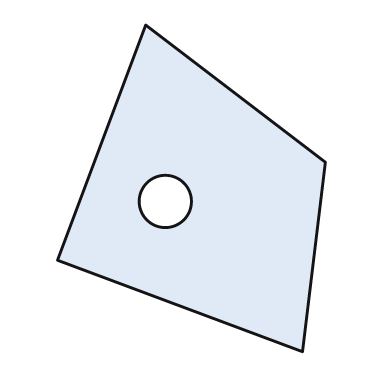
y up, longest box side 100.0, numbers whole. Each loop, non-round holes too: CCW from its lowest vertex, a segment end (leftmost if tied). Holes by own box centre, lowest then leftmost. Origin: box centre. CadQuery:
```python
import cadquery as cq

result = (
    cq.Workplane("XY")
    .moveTo(34.0, -50.0)
    .lineTo(41.0, 8.0)
    .lineTo(-14.0, 50.0)
    .lineTo(-41.0, -22.0)
    .close()
    .moveTo(-8.0, -4.0)
    .circle(8.0)
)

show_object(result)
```